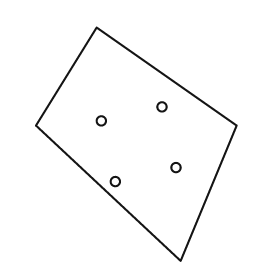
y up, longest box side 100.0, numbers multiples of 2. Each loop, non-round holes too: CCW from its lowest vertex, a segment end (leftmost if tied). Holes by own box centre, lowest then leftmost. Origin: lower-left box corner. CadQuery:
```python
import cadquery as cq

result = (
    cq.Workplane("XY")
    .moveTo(62.0, 0.0)
    .lineTo(86.0, 58.0)
    .lineTo(26.0, 100.0)
    .lineTo(0.0, 58.0)
    .close()
    .moveTo(34.0, 34.0)
    .circle(2.0)
    .moveTo(60.0, 40.0)
    .circle(2.0)
    .moveTo(28.0, 60.0)
    .circle(2.0)
    .moveTo(54.0, 66.0)
    .circle(2.0)
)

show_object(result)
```